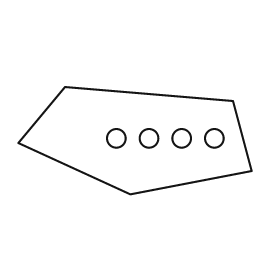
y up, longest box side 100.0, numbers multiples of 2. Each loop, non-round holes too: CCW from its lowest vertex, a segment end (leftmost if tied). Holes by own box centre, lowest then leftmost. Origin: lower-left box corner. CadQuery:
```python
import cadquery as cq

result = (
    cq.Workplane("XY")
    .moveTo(48.0, 0.0)
    .lineTo(100.0, 10.0)
    .lineTo(92.0, 40.0)
    .lineTo(20.0, 46.0)
    .lineTo(0.0, 22.0)
    .close()
    .moveTo(42.0, 24.0)
    .circle(4.0)
    .moveTo(56.0, 24.0)
    .circle(4.0)
    .moveTo(70.0, 24.0)
    .circle(4.0)
    .moveTo(84.0, 24.0)
    .circle(4.0)
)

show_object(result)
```